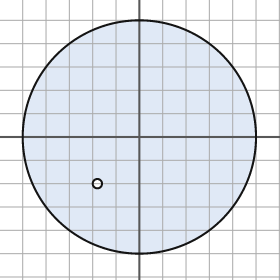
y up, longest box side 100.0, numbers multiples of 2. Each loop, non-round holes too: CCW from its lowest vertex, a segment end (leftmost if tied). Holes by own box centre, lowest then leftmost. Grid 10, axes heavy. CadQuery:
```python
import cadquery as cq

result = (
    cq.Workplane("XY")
    .moveTo(0.0, 0.0)
    .circle(50.0)
    .moveTo(-18.0, -20.0)
    .circle(2.0)
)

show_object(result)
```